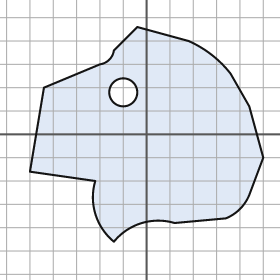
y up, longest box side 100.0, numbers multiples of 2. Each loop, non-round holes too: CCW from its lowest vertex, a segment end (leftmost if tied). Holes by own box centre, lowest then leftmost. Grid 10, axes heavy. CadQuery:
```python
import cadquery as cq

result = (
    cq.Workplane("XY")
    .moveTo(-14.0, -46.0)
    .threePointArc((-2.0, -38.0), (12.0, -38.0))
    .lineTo(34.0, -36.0)
    .threePointArc((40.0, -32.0), (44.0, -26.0))
    .lineTo(50.0, -10.0)
    .lineTo(44.0, 12.0)
    .lineTo(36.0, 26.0)
    .threePointArc((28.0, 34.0), (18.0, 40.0))
    .lineTo(-4.0, 46.0)
    .lineTo(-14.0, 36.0)
    .threePointArc((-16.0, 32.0), (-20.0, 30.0))
    .lineTo(-44.0, 20.0)
    .lineTo(-50.0, -16.0)
    .lineTo(-22.0, -20.0)
    .threePointArc((-22.0, -34.0), (-14.0, -46.0))
    .close()
    .moveTo(-10.0, 18.0)
    .circle(6.0)
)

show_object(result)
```